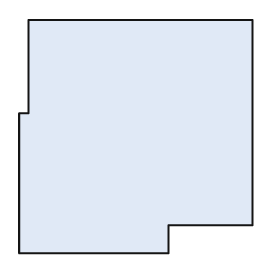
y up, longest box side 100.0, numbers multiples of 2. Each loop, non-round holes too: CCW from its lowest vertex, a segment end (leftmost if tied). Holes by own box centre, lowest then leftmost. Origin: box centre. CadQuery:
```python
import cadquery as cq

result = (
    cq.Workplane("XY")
    .moveTo(-50.0, -50.0)
    .lineTo(14.0, -50.0)
    .lineTo(14.0, -38.0)
    .lineTo(50.0, -38.0)
    .lineTo(50.0, 50.0)
    .lineTo(-46.0, 50.0)
    .lineTo(-46.0, 10.0)
    .lineTo(-50.0, 10.0)
    .close()
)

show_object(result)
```